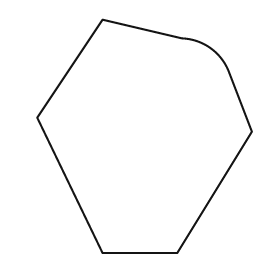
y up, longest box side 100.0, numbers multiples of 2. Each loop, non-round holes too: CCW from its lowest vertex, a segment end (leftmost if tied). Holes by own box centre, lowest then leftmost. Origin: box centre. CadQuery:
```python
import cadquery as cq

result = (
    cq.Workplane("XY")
    .moveTo(-18.0, -50.0)
    .lineTo(14.0, -50.0)
    .lineTo(46.0, 2.0)
    .lineTo(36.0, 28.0)
    .threePointArc((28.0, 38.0), (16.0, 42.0))
    .lineTo(-18.0, 50.0)
    .lineTo(-46.0, 8.0)
    .close()
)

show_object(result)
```